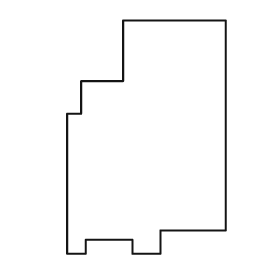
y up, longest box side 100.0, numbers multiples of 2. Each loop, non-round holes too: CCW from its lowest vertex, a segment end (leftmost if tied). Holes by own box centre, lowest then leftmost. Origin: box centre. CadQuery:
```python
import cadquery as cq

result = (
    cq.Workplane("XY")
    .moveTo(-34.0, -50.0)
    .lineTo(-26.0, -50.0)
    .lineTo(-26.0, -44.0)
    .lineTo(-6.0, -44.0)
    .lineTo(-6.0, -50.0)
    .lineTo(6.0, -50.0)
    .lineTo(6.0, -40.0)
    .lineTo(34.0, -40.0)
    .lineTo(34.0, 50.0)
    .lineTo(-10.0, 50.0)
    .lineTo(-10.0, 24.0)
    .lineTo(-28.0, 24.0)
    .lineTo(-28.0, 10.0)
    .lineTo(-34.0, 10.0)
    .close()
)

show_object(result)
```